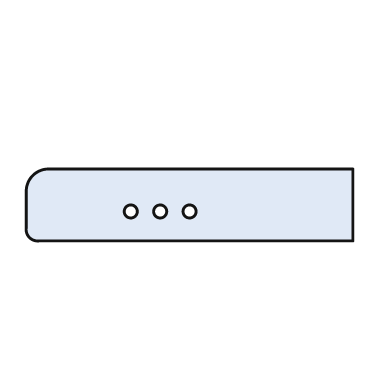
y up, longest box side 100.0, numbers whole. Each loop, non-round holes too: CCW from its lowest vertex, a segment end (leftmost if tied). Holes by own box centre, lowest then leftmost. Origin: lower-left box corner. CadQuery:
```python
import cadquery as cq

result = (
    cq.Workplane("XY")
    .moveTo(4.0, 0.0)
    .lineTo(100.0, 0.0)
    .lineTo(100.0, 22.0)
    .lineTo(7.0, 22.0)
    .threePointArc((2.0, 20.0), (0.0, 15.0))
    .lineTo(0.0, 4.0)
    .threePointArc((1.0, 1.0), (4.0, 0.0))
    .close()
    .moveTo(32.0, 9.0)
    .circle(2.0)
    .moveTo(41.0, 9.0)
    .circle(2.0)
    .moveTo(50.0, 9.0)
    .circle(2.0)
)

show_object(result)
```